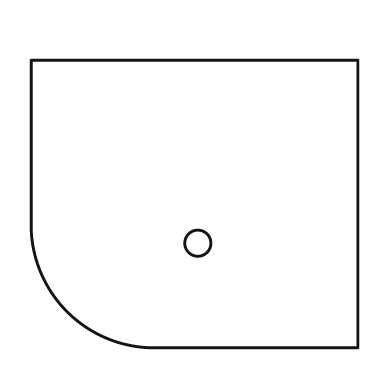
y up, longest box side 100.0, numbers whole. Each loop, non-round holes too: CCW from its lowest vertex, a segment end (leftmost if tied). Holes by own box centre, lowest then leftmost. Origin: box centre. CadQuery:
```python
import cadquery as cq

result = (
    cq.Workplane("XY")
    .moveTo(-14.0, -44.0)
    .lineTo(50.0, -44.0)
    .lineTo(50.0, 44.0)
    .lineTo(-50.0, 44.0)
    .lineTo(-50.0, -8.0)
    .threePointArc((-39.0, -33.0), (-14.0, -44.0))
    .close()
    .moveTo(1.0, -12.0)
    .circle(4.0)
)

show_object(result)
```